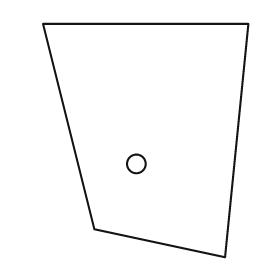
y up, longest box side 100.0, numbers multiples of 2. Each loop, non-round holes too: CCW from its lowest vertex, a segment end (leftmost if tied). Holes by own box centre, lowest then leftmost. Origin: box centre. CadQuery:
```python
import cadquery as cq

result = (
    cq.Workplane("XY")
    .moveTo(34.0, -50.0)
    .lineTo(44.0, 50.0)
    .lineTo(-44.0, 50.0)
    .lineTo(-22.0, -38.0)
    .close()
    .moveTo(-4.0, -10.0)
    .circle(4.0)
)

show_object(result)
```